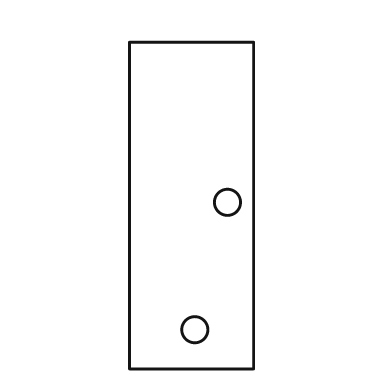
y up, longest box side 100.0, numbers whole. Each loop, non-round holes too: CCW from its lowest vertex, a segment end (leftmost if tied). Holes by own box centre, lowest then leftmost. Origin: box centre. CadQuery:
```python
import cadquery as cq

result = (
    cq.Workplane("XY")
    .moveTo(-19.0, -50.0)
    .lineTo(19.0, -50.0)
    .lineTo(19.0, 50.0)
    .lineTo(-19.0, 50.0)
    .close()
    .moveTo(1.0, -38.0)
    .circle(4.0)
    .moveTo(11.0, 1.0)
    .circle(4.0)
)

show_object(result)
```